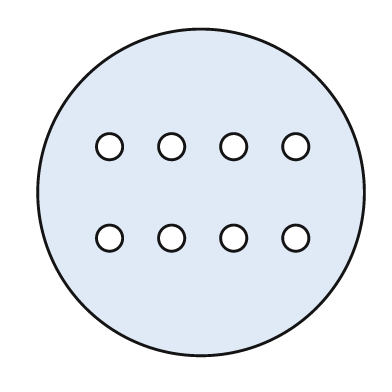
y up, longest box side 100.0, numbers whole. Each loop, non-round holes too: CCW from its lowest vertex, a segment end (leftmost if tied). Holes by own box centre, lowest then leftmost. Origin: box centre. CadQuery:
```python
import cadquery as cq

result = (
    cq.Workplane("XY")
    .moveTo(0.0, 0.0)
    .circle(50.0)
    .moveTo(-28.0, -14.0)
    .circle(4.0)
    .moveTo(-9.0, -14.0)
    .circle(4.0)
    .moveTo(10.0, -14.0)
    .circle(4.0)
    .moveTo(29.0, -14.0)
    .circle(4.0)
    .moveTo(-28.0, 14.0)
    .circle(4.0)
    .moveTo(-9.0, 14.0)
    .circle(4.0)
    .moveTo(10.0, 14.0)
    .circle(4.0)
    .moveTo(29.0, 14.0)
    .circle(4.0)
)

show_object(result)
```